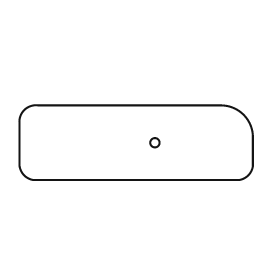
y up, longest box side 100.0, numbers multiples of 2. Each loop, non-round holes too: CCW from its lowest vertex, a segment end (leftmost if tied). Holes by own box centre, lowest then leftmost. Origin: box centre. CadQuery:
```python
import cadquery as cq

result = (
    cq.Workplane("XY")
    .moveTo(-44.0, -16.0)
    .lineTo(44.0, -16.0)
    .threePointArc((48.0, -14.0), (50.0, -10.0))
    .lineTo(50.0, 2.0)
    .threePointArc((46.0, 12.0), (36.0, 16.0))
    .lineTo(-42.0, 16.0)
    .threePointArc((-48.0, 14.0), (-50.0, 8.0))
    .lineTo(-50.0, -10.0)
    .threePointArc((-48.0, -14.0), (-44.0, -16.0))
    .close()
    .moveTo(8.0, 0.0)
    .circle(2.0)
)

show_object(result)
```